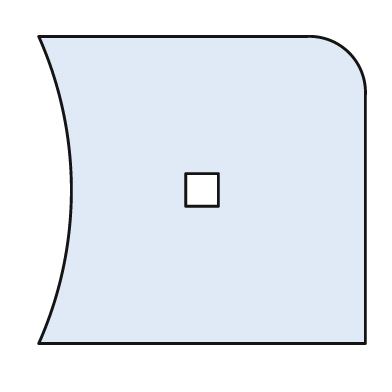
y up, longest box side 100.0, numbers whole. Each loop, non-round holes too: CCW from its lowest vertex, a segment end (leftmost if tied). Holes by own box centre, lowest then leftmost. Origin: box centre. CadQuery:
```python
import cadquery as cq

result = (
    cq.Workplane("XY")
    .moveTo(-50.0, -47.0)
    .lineTo(50.0, -47.0)
    .lineTo(50.0, 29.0)
    .threePointArc((45.0, 42.0), (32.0, 47.0))
    .lineTo(-50.0, 47.0)
    .threePointArc((-40.0, 0.0), (-50.0, -47.0))
    .close()
    .moveTo(-5.0, -5.0)
    .lineTo(5.0, -5.0)
    .lineTo(5.0, 5.0)
    .lineTo(-5.0, 5.0)
    .close()
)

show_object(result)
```